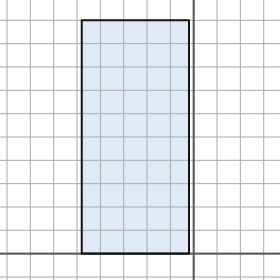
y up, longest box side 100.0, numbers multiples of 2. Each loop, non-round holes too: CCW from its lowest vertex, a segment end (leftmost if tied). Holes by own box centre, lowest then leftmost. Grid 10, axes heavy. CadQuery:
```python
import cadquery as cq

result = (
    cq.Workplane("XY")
    .moveTo(-48.0, 0.0)
    .lineTo(-2.0, 0.0)
    .lineTo(-2.0, 100.0)
    .lineTo(-48.0, 100.0)
    .close()
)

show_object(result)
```